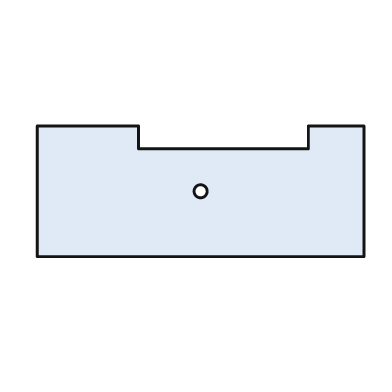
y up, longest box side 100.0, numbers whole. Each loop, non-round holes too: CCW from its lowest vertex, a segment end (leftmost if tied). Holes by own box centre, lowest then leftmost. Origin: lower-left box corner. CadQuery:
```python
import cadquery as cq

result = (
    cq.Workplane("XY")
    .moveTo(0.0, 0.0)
    .lineTo(100.0, 0.0)
    .lineTo(100.0, 40.0)
    .lineTo(83.0, 40.0)
    .lineTo(83.0, 33.0)
    .lineTo(31.0, 33.0)
    .lineTo(31.0, 40.0)
    .lineTo(0.0, 40.0)
    .close()
    .moveTo(50.0, 20.0)
    .circle(2.0)
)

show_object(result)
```